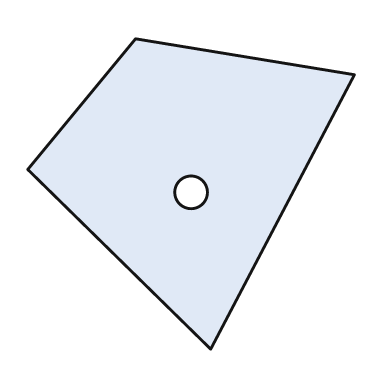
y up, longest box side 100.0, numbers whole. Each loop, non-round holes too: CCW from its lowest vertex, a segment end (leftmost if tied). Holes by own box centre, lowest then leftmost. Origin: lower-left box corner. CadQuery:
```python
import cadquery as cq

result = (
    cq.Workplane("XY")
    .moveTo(56.0, 0.0)
    .lineTo(100.0, 84.0)
    .lineTo(33.0, 95.0)
    .lineTo(0.0, 55.0)
    .close()
    .moveTo(50.0, 48.0)
    .circle(5.0)
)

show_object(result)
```